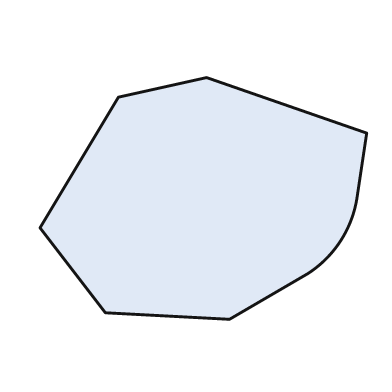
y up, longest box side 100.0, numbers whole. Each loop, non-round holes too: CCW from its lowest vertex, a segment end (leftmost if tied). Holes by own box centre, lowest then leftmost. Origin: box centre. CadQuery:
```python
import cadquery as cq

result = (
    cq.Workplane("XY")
    .moveTo(8.0, -37.0)
    .lineTo(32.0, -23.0)
    .threePointArc((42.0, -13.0), (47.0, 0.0))
    .lineTo(50.0, 20.0)
    .lineTo(1.0, 37.0)
    .lineTo(-26.0, 31.0)
    .lineTo(-50.0, -9.0)
    .lineTo(-30.0, -35.0)
    .close()
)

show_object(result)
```